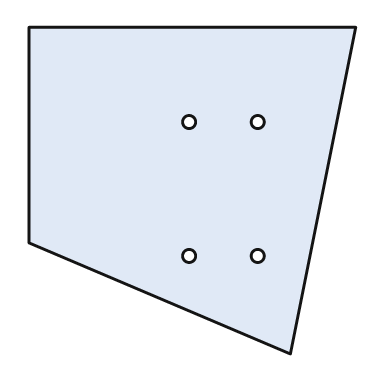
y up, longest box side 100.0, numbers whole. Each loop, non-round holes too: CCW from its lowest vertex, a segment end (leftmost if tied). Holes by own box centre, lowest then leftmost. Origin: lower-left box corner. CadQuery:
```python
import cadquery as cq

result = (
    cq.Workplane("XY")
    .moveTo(80.0, 0.0)
    .lineTo(100.0, 100.0)
    .lineTo(0.0, 100.0)
    .lineTo(0.0, 34.0)
    .close()
    .moveTo(49.0, 30.0)
    .circle(2.0)
    .moveTo(70.0, 30.0)
    .circle(2.0)
    .moveTo(49.0, 71.0)
    .circle(2.0)
    .moveTo(70.0, 71.0)
    .circle(2.0)
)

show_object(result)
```